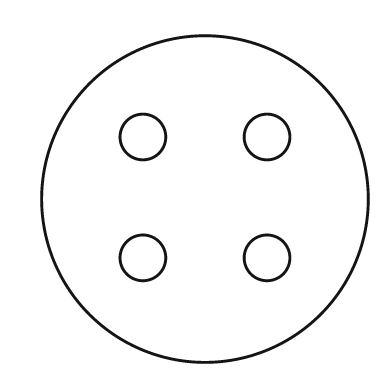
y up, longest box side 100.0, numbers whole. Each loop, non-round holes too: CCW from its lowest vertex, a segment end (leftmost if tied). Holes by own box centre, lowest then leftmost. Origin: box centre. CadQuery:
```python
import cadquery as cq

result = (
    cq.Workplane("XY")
    .moveTo(0.0, 0.0)
    .circle(50.0)
    .moveTo(-19.0, -18.0)
    .circle(7.0)
    .moveTo(19.0, -18.0)
    .circle(7.0)
    .moveTo(-19.0, 19.0)
    .circle(7.0)
    .moveTo(19.0, 19.0)
    .circle(7.0)
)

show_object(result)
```